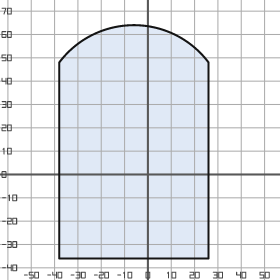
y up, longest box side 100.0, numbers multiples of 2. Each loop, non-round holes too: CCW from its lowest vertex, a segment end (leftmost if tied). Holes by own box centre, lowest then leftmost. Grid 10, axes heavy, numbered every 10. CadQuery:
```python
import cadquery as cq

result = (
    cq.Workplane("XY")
    .moveTo(-38.0, -36.0)
    .lineTo(26.0, -36.0)
    .lineTo(26.0, 48.0)
    .threePointArc((-6.0, 64.0), (-38.0, 48.0))
    .close()
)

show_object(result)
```